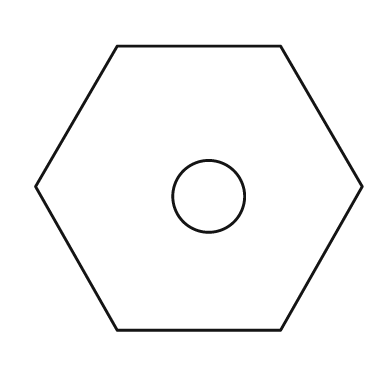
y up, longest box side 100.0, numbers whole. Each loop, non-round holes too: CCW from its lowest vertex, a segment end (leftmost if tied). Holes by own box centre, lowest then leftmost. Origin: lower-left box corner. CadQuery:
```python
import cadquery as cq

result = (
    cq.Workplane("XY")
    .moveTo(25.0, 0.0)
    .lineTo(75.0, 0.0)
    .lineTo(100.0, 44.0)
    .lineTo(75.0, 87.0)
    .lineTo(25.0, 87.0)
    .lineTo(0.0, 44.0)
    .close()
    .moveTo(53.0, 41.0)
    .circle(11.0)
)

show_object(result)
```